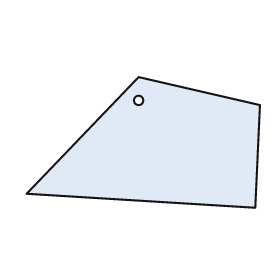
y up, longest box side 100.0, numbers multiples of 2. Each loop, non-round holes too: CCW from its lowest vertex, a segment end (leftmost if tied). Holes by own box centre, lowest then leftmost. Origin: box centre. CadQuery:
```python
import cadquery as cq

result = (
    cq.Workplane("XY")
    .moveTo(48.0, -28.0)
    .lineTo(50.0, 16.0)
    .lineTo(-2.0, 28.0)
    .lineTo(-50.0, -22.0)
    .close()
    .moveTo(-2.0, 18.0)
    .circle(2.0)
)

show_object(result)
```